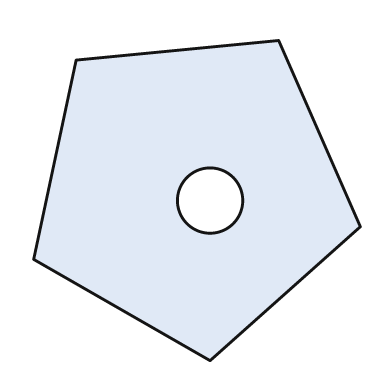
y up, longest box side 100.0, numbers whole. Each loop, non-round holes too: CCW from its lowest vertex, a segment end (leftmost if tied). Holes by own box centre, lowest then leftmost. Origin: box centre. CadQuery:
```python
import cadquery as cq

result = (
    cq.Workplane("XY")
    .moveTo(4.0, -49.0)
    .lineTo(50.0, -8.0)
    .lineTo(25.0, 49.0)
    .lineTo(-37.0, 43.0)
    .lineTo(-50.0, -18.0)
    .close()
    .moveTo(4.0, 0.0)
    .circle(10.0)
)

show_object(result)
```